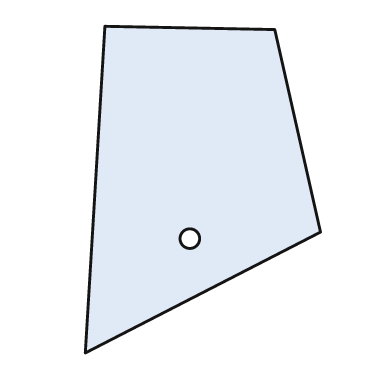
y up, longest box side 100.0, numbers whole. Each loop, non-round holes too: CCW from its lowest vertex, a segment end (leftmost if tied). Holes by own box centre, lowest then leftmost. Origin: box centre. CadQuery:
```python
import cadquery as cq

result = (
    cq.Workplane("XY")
    .moveTo(-36.0, -50.0)
    .lineTo(36.0, -13.0)
    .lineTo(22.0, 49.0)
    .lineTo(-30.0, 50.0)
    .close()
    .moveTo(-4.0, -15.0)
    .circle(3.0)
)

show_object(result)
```